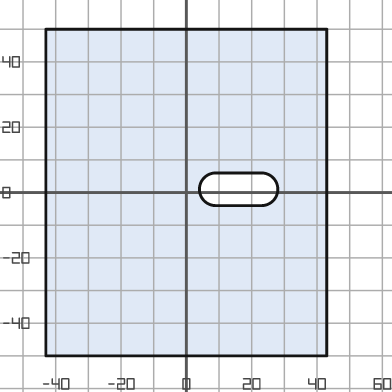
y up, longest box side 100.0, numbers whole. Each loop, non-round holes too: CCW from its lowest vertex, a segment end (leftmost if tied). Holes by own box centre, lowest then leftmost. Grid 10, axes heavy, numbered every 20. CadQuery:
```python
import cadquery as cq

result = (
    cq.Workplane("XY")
    .moveTo(-43.0, -50.0)
    .lineTo(43.0, -50.0)
    .lineTo(43.0, 50.0)
    .lineTo(-43.0, 50.0)
    .close()
    .moveTo(9.0, -4.0)
    .lineTo(23.0, -4.0)
    .threePointArc((28.0, 1.0), (23.0, 6.0))
    .lineTo(9.0, 6.0)
    .threePointArc((4.0, 1.0), (9.0, -4.0))
    .close()
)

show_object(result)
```